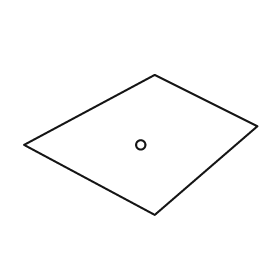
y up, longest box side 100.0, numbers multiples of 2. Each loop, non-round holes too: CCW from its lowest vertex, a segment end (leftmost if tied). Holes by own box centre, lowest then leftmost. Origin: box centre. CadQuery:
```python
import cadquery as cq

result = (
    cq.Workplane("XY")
    .moveTo(6.0, -30.0)
    .lineTo(50.0, 8.0)
    .lineTo(6.0, 30.0)
    .lineTo(-50.0, 0.0)
    .close()
    .moveTo(0.0, 0.0)
    .circle(2.0)
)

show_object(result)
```